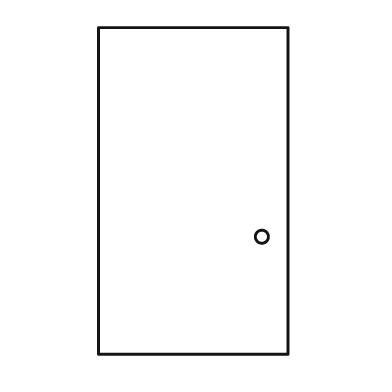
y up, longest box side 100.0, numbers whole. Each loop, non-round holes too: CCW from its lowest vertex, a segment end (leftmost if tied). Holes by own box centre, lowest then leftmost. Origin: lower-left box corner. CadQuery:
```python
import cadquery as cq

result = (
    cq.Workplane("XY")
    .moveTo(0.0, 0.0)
    .lineTo(58.0, 0.0)
    .lineTo(58.0, 100.0)
    .lineTo(0.0, 100.0)
    .close()
    .moveTo(50.0, 36.0)
    .circle(2.0)
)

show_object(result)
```